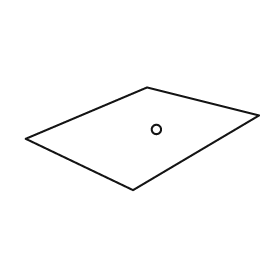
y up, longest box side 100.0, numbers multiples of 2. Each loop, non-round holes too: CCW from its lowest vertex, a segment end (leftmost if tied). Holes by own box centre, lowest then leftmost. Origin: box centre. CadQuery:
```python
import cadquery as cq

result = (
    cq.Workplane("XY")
    .moveTo(-4.0, -22.0)
    .lineTo(50.0, 10.0)
    .lineTo(2.0, 22.0)
    .lineTo(-50.0, 0.0)
    .close()
    .moveTo(6.0, 4.0)
    .circle(2.0)
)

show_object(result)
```